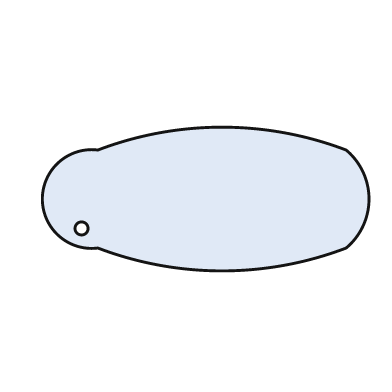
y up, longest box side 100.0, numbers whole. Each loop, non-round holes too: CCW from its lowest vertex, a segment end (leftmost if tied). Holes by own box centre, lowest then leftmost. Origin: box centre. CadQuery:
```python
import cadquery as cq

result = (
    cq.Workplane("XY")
    .moveTo(-33.0, -15.0)
    .threePointArc((5.0, -22.0), (43.0, -15.0))
    .threePointArc((50.0, 0.0), (43.0, 15.0))
    .threePointArc((5.0, 22.0), (-33.0, 15.0))
    .threePointArc((-50.0, 0.0), (-33.0, -15.0))
    .close()
    .moveTo(-38.0, -9.0)
    .circle(2.0)
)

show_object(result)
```